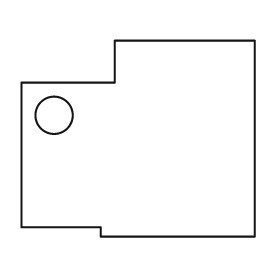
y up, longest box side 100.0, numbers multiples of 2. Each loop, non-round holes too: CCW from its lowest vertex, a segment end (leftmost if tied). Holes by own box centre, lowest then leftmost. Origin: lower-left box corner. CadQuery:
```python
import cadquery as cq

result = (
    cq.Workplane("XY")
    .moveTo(34.0, 0.0)
    .lineTo(100.0, 0.0)
    .lineTo(100.0, 84.0)
    .lineTo(40.0, 84.0)
    .lineTo(40.0, 66.0)
    .lineTo(0.0, 66.0)
    .lineTo(0.0, 4.0)
    .lineTo(34.0, 4.0)
    .close()
    .moveTo(14.0, 52.0)
    .circle(8.0)
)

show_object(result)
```